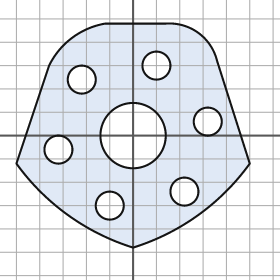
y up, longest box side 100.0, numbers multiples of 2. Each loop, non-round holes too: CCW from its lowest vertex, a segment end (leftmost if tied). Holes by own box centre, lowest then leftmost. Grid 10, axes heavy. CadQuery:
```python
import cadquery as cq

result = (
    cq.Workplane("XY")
    .moveTo(0.0, -48.0)
    .threePointArc((28.0, -34.0), (50.0, -12.0))
    .lineTo(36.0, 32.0)
    .threePointArc((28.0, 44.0), (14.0, 48.0))
    .lineTo(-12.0, 48.0)
    .threePointArc((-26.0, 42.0), (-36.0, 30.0))
    .lineTo(-50.0, -12.0)
    .threePointArc((-28.0, -34.0), (0.0, -48.0))
    .close()
    .moveTo(-10.0, -30.0)
    .circle(6.0)
    .moveTo(22.0, -24.0)
    .circle(6.0)
    .moveTo(-32.0, -6.0)
    .circle(6.0)
    .moveTo(0.0, 0.0)
    .circle(14.0)
    .moveTo(32.0, 6.0)
    .circle(6.0)
    .moveTo(-22.0, 24.0)
    .circle(6.0)
    .moveTo(10.0, 30.0)
    .circle(6.0)
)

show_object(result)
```